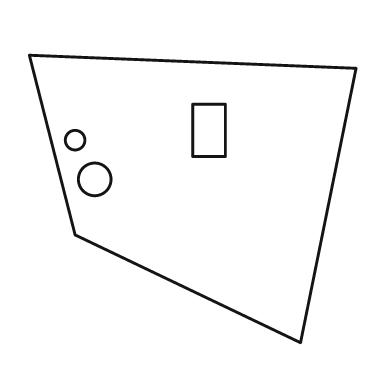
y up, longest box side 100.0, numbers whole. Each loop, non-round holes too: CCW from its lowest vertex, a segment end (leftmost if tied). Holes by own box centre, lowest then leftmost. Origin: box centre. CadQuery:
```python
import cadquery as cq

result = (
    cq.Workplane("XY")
    .moveTo(33.0, -44.0)
    .lineTo(50.0, 40.0)
    .lineTo(-50.0, 44.0)
    .lineTo(-36.0, -11.0)
    .close()
    .moveTo(-30.0, 6.0)
    .circle(5.0)
    .moveTo(-36.0, 18.0)
    .circle(3.0)
    .moveTo(0.0, 13.0)
    .lineTo(10.0, 13.0)
    .lineTo(10.0, 29.0)
    .lineTo(0.0, 29.0)
    .close()
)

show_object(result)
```